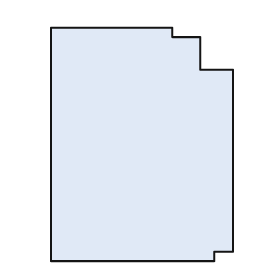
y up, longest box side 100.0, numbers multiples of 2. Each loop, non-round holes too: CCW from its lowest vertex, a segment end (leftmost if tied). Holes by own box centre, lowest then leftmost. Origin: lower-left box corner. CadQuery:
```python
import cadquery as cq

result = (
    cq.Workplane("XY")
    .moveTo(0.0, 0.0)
    .lineTo(70.0, 0.0)
    .lineTo(70.0, 4.0)
    .lineTo(78.0, 4.0)
    .lineTo(78.0, 82.0)
    .lineTo(64.0, 82.0)
    .lineTo(64.0, 96.0)
    .lineTo(52.0, 96.0)
    .lineTo(52.0, 100.0)
    .lineTo(0.0, 100.0)
    .close()
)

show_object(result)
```